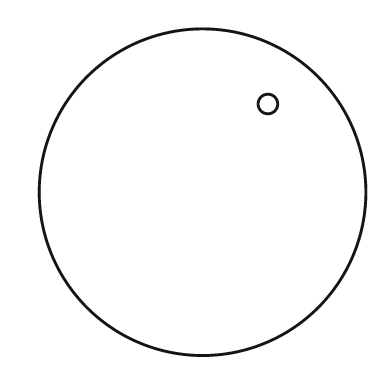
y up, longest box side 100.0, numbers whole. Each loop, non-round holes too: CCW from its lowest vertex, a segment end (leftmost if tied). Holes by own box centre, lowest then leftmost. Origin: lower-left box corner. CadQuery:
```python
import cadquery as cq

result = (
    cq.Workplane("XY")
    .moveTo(50.0, 50.0)
    .circle(50.0)
    .moveTo(70.0, 77.0)
    .circle(3.0)
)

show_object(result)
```